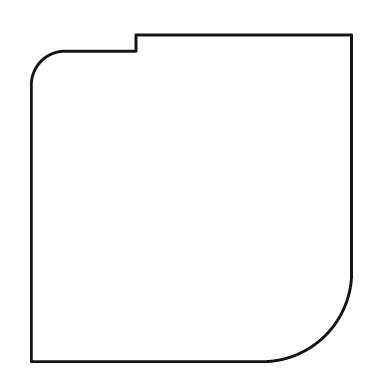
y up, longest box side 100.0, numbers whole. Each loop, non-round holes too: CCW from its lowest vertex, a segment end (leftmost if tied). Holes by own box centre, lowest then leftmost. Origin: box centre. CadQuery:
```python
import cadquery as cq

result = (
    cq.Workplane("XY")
    .moveTo(-49.0, -50.0)
    .lineTo(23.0, -50.0)
    .threePointArc((41.0, -42.0), (49.0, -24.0))
    .lineTo(49.0, 50.0)
    .lineTo(-17.0, 50.0)
    .lineTo(-17.0, 45.0)
    .lineTo(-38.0, 45.0)
    .threePointArc((-46.0, 42.0), (-49.0, 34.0))
    .close()
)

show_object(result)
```